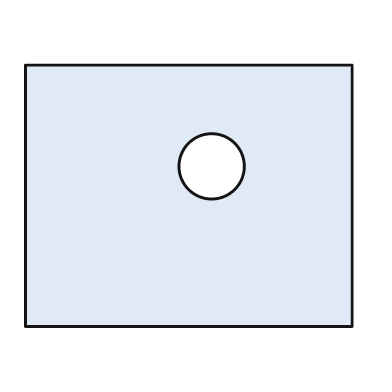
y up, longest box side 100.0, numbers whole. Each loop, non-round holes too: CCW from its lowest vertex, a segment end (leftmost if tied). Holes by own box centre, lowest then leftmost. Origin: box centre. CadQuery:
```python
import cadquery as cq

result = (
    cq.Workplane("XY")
    .moveTo(-50.0, -40.0)
    .lineTo(50.0, -40.0)
    .lineTo(50.0, 40.0)
    .lineTo(-50.0, 40.0)
    .close()
    .moveTo(7.0, 9.0)
    .circle(10.0)
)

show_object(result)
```